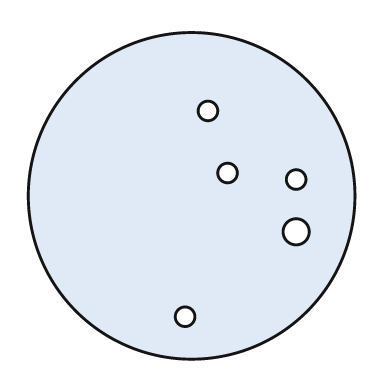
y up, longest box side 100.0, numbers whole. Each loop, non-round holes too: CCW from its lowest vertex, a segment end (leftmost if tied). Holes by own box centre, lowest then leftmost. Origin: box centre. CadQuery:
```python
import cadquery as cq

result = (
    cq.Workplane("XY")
    .moveTo(0.0, 0.0)
    .circle(50.0)
    .moveTo(-2.0, -37.0)
    .circle(3.0)
    .moveTo(32.0, -11.0)
    .circle(4.0)
    .moveTo(32.0, 5.0)
    .circle(3.0)
    .moveTo(11.0, 7.0)
    .circle(3.0)
    .moveTo(5.0, 26.0)
    .circle(3.0)
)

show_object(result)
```